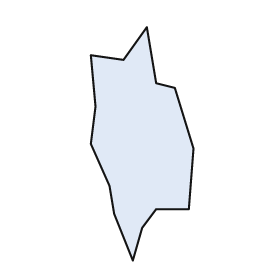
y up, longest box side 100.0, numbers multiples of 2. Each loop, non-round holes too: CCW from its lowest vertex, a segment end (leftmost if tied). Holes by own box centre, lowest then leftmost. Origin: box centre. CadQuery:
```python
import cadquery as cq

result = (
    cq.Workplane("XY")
    .moveTo(-4.0, -50.0)
    .lineTo(0.0, -36.0)
    .lineTo(6.0, -28.0)
    .lineTo(20.0, -28.0)
    .lineTo(22.0, -2.0)
    .lineTo(14.0, 24.0)
    .lineTo(6.0, 26.0)
    .lineTo(2.0, 50.0)
    .lineTo(-8.0, 36.0)
    .lineTo(-22.0, 38.0)
    .lineTo(-20.0, 16.0)
    .lineTo(-22.0, 0.0)
    .lineTo(-14.0, -18.0)
    .lineTo(-12.0, -30.0)
    .close()
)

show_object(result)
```